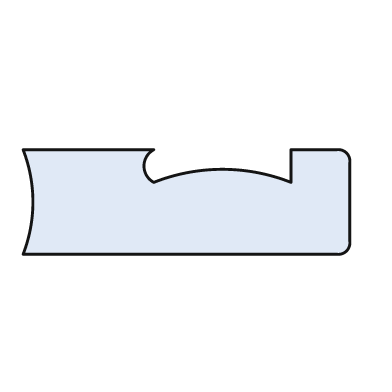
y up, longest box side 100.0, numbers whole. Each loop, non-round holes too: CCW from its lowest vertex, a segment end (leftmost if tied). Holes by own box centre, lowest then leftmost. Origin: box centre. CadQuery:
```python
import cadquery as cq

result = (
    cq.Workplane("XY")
    .moveTo(-50.0, -16.0)
    .lineTo(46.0, -16.0)
    .threePointArc((49.0, -15.0), (50.0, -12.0))
    .lineTo(50.0, 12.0)
    .threePointArc((49.0, 15.0), (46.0, 16.0))
    .lineTo(32.0, 16.0)
    .lineTo(32.0, 6.0)
    .threePointArc((11.0, 10.0), (-10.0, 6.0))
    .threePointArc((-13.0, 11.0), (-10.0, 16.0))
    .lineTo(-50.0, 16.0)
    .threePointArc((-47.0, 0.0), (-50.0, -16.0))
    .close()
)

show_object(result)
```